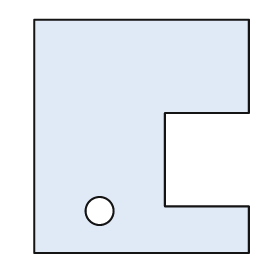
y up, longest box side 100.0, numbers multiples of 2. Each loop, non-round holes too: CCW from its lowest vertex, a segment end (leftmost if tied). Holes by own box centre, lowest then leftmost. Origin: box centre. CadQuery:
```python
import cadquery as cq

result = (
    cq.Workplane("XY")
    .moveTo(-46.0, -50.0)
    .lineTo(46.0, -50.0)
    .lineTo(46.0, -30.0)
    .lineTo(10.0, -30.0)
    .lineTo(10.0, 10.0)
    .lineTo(46.0, 10.0)
    .lineTo(46.0, 50.0)
    .lineTo(-46.0, 50.0)
    .close()
    .moveTo(-18.0, -32.0)
    .circle(6.0)
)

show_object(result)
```